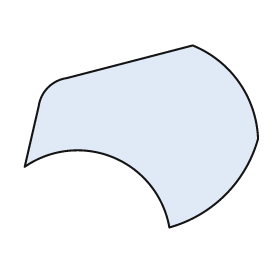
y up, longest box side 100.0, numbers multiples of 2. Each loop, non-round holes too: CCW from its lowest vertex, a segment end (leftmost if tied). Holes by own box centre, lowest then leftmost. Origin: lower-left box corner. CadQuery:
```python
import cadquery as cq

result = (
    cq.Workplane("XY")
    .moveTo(62.0, 0.0)
    .threePointArc((86.0, 14.0), (100.0, 38.0))
    .threePointArc((92.0, 62.0), (72.0, 78.0))
    .lineTo(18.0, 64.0)
    .threePointArc((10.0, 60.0), (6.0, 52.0))
    .lineTo(0.0, 26.0)
    .threePointArc((38.0, 30.0), (62.0, 0.0))
    .close()
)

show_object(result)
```